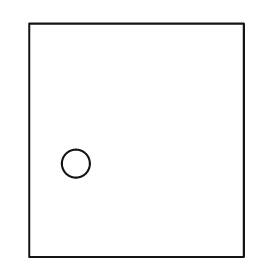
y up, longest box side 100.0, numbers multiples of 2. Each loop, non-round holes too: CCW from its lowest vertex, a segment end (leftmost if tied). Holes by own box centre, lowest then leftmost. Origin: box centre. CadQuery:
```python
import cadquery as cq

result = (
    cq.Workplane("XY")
    .moveTo(-46.0, -50.0)
    .lineTo(46.0, -50.0)
    .lineTo(46.0, 50.0)
    .lineTo(-46.0, 50.0)
    .close()
    .moveTo(-26.0, -10.0)
    .circle(6.0)
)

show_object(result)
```